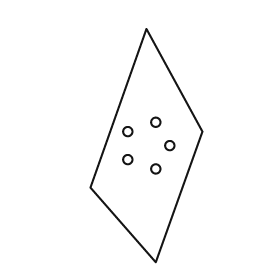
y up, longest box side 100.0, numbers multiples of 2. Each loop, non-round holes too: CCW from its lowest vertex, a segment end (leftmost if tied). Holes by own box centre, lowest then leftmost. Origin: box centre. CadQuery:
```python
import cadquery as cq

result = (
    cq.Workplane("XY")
    .moveTo(4.0, -50.0)
    .lineTo(24.0, 6.0)
    .lineTo(0.0, 50.0)
    .lineTo(-24.0, -18.0)
    .close()
    .moveTo(4.0, -10.0)
    .circle(2.0)
    .moveTo(-8.0, -6.0)
    .circle(2.0)
    .moveTo(10.0, 0.0)
    .circle(2.0)
    .moveTo(-8.0, 6.0)
    .circle(2.0)
    .moveTo(4.0, 10.0)
    .circle(2.0)
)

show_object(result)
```